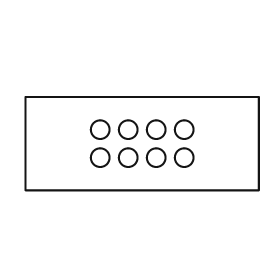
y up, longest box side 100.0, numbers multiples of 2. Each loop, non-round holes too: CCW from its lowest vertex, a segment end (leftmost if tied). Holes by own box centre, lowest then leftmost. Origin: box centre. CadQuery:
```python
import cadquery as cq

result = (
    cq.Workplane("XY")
    .moveTo(-50.0, -20.0)
    .lineTo(50.0, -20.0)
    .lineTo(50.0, 20.0)
    .lineTo(-50.0, 20.0)
    .close()
    .moveTo(-18.0, -6.0)
    .circle(4.0)
    .moveTo(-6.0, -6.0)
    .circle(4.0)
    .moveTo(6.0, -6.0)
    .circle(4.0)
    .moveTo(18.0, -6.0)
    .circle(4.0)
    .moveTo(-18.0, 6.0)
    .circle(4.0)
    .moveTo(-6.0, 6.0)
    .circle(4.0)
    .moveTo(6.0, 6.0)
    .circle(4.0)
    .moveTo(18.0, 6.0)
    .circle(4.0)
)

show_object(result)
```